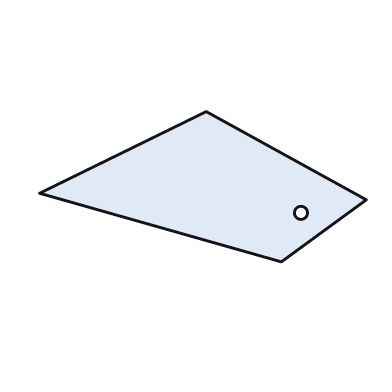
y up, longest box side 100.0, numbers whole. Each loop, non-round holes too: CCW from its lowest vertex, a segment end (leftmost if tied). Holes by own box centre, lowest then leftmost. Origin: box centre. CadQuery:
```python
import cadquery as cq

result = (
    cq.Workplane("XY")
    .moveTo(24.0, -23.0)
    .lineTo(50.0, -4.0)
    .lineTo(1.0, 23.0)
    .lineTo(-50.0, -2.0)
    .close()
    .moveTo(30.0, -8.0)
    .circle(2.0)
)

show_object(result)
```